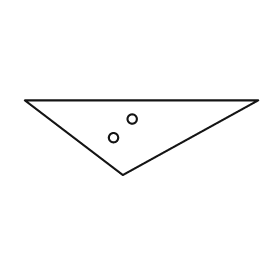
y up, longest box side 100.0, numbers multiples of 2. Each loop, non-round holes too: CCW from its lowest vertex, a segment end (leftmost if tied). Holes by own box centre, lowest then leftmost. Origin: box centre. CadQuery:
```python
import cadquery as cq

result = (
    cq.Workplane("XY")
    .moveTo(-8.0, -16.0)
    .lineTo(50.0, 16.0)
    .lineTo(-50.0, 16.0)
    .close()
    .moveTo(-12.0, 0.0)
    .circle(2.0)
    .moveTo(-4.0, 8.0)
    .circle(2.0)
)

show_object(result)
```